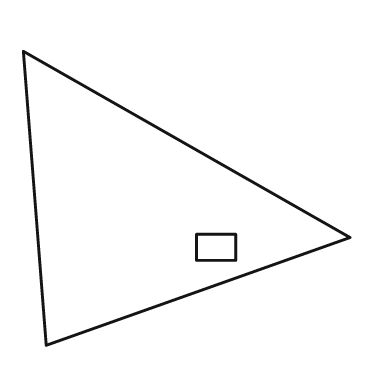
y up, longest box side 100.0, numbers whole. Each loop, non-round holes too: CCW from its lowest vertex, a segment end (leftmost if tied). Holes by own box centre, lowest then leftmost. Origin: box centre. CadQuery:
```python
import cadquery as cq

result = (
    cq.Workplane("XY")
    .moveTo(-43.0, -45.0)
    .lineTo(50.0, -12.0)
    .lineTo(-50.0, 45.0)
    .close()
    .moveTo(3.0, -19.0)
    .lineTo(15.0, -19.0)
    .lineTo(15.0, -11.0)
    .lineTo(3.0, -11.0)
    .close()
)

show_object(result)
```